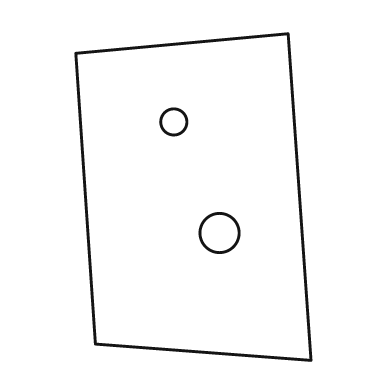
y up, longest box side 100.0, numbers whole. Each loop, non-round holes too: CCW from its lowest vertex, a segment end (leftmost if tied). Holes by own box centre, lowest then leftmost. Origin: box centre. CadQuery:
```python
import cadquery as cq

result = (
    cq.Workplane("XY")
    .moveTo(36.0, -50.0)
    .lineTo(29.0, 50.0)
    .lineTo(-36.0, 44.0)
    .lineTo(-30.0, -45.0)
    .close()
    .moveTo(8.0, -11.0)
    .circle(6.0)
    .moveTo(-6.0, 23.0)
    .circle(4.0)
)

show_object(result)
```